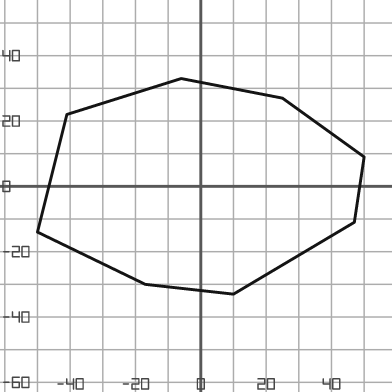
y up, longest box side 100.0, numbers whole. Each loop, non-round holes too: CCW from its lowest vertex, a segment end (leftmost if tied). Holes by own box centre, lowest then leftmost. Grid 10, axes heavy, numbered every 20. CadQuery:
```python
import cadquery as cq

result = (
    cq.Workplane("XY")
    .moveTo(10.0, -33.0)
    .lineTo(47.0, -11.0)
    .lineTo(50.0, 9.0)
    .lineTo(25.0, 27.0)
    .lineTo(-6.0, 33.0)
    .lineTo(-41.0, 22.0)
    .lineTo(-50.0, -14.0)
    .lineTo(-17.0, -30.0)
    .close()
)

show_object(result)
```